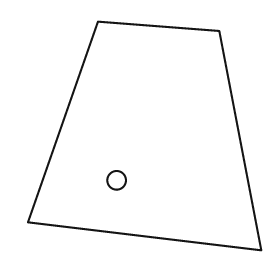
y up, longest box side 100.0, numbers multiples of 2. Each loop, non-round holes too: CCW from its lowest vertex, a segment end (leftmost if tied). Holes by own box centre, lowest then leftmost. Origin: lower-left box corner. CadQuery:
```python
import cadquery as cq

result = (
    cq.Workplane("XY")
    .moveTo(100.0, 0.0)
    .lineTo(82.0, 94.0)
    .lineTo(30.0, 98.0)
    .lineTo(0.0, 12.0)
    .close()
    .moveTo(38.0, 30.0)
    .circle(4.0)
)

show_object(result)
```